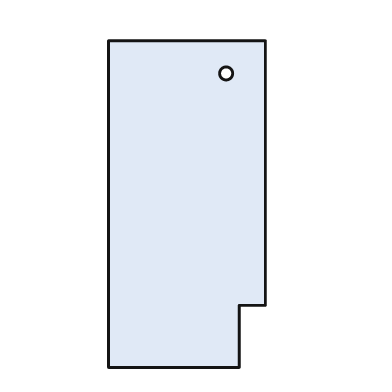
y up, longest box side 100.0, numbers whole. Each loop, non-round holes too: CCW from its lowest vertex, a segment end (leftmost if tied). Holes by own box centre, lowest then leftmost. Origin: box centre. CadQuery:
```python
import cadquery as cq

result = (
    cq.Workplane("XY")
    .moveTo(-24.0, -50.0)
    .lineTo(16.0, -50.0)
    .lineTo(16.0, -31.0)
    .lineTo(24.0, -31.0)
    .lineTo(24.0, 50.0)
    .lineTo(-24.0, 50.0)
    .close()
    .moveTo(12.0, 40.0)
    .circle(2.0)
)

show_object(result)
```